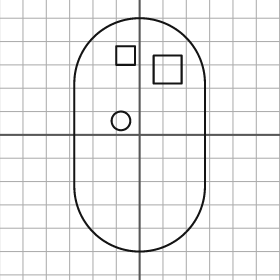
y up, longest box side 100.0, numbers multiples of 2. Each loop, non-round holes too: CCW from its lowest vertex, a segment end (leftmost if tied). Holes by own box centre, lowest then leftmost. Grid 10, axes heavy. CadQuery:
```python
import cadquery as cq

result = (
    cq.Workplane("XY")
    .moveTo(-28.0, -22.0)
    .threePointArc((0.0, -50.0), (28.0, -22.0))
    .lineTo(28.0, 22.0)
    .threePointArc((0.0, 50.0), (-28.0, 22.0))
    .close()
    .moveTo(-8.0, 6.0)
    .circle(4.0)
    .moveTo(6.0, 22.0)
    .lineTo(18.0, 22.0)
    .lineTo(18.0, 34.0)
    .lineTo(6.0, 34.0)
    .close()
    .moveTo(-10.0, 30.0)
    .lineTo(-2.0, 30.0)
    .lineTo(-2.0, 38.0)
    .lineTo(-10.0, 38.0)
    .close()
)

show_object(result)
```